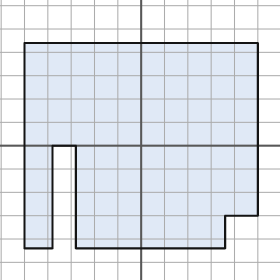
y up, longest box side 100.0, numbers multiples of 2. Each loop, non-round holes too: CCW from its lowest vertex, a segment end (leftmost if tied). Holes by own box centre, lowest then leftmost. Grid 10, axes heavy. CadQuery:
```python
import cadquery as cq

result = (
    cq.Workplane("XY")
    .moveTo(-50.0, -44.0)
    .lineTo(-38.0, -44.0)
    .lineTo(-38.0, 0.0)
    .lineTo(-28.0, 0.0)
    .lineTo(-28.0, -44.0)
    .lineTo(36.0, -44.0)
    .lineTo(36.0, -30.0)
    .lineTo(50.0, -30.0)
    .lineTo(50.0, 44.0)
    .lineTo(-50.0, 44.0)
    .close()
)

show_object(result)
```